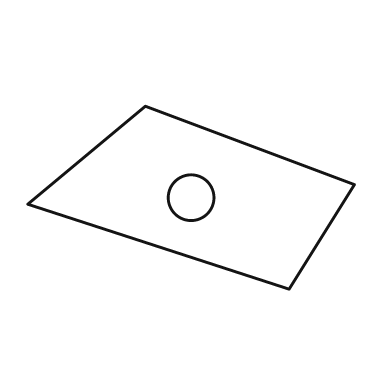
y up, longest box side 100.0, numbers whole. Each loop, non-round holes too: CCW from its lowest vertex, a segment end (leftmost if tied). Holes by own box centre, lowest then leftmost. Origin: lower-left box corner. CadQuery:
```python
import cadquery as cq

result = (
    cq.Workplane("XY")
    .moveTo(80.0, 0.0)
    .lineTo(100.0, 32.0)
    .lineTo(36.0, 56.0)
    .lineTo(0.0, 26.0)
    .close()
    .moveTo(50.0, 28.0)
    .circle(7.0)
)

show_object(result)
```